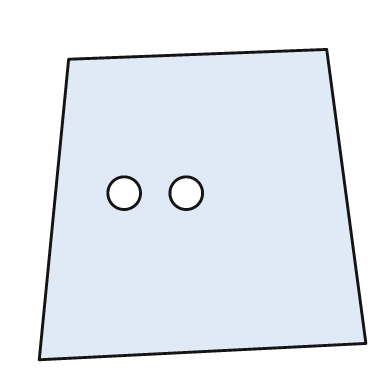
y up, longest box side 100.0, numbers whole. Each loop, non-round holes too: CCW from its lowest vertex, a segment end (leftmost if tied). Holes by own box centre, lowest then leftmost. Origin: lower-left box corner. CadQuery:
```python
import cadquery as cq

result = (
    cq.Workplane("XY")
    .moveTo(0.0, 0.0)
    .lineTo(100.0, 5.0)
    .lineTo(88.0, 95.0)
    .lineTo(9.0, 92.0)
    .close()
    .moveTo(26.0, 51.0)
    .circle(5.0)
    .moveTo(45.0, 51.0)
    .circle(5.0)
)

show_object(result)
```